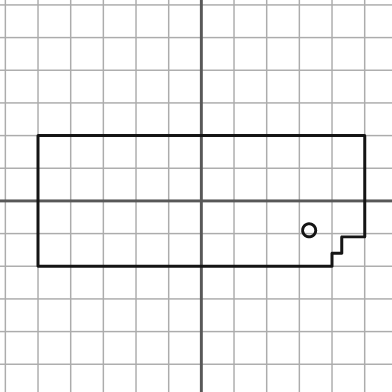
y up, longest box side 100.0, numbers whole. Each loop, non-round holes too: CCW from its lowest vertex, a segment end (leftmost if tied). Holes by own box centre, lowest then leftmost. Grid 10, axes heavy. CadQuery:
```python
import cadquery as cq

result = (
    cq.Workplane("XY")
    .moveTo(-50.0, -20.0)
    .lineTo(40.0, -20.0)
    .lineTo(40.0, -16.0)
    .lineTo(43.0, -16.0)
    .lineTo(43.0, -11.0)
    .lineTo(50.0, -11.0)
    .lineTo(50.0, 20.0)
    .lineTo(-50.0, 20.0)
    .close()
    .moveTo(33.0, -9.0)
    .circle(2.0)
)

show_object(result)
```